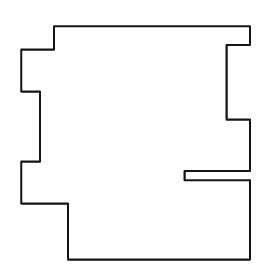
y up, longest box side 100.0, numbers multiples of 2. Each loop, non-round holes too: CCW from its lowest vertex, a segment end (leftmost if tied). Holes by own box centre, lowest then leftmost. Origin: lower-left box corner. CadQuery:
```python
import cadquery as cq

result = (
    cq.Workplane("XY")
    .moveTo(20.0, 0.0)
    .lineTo(98.0, 0.0)
    .lineTo(98.0, 34.0)
    .lineTo(70.0, 34.0)
    .lineTo(70.0, 38.0)
    .lineTo(98.0, 38.0)
    .lineTo(98.0, 60.0)
    .lineTo(88.0, 60.0)
    .lineTo(88.0, 92.0)
    .lineTo(98.0, 92.0)
    .lineTo(98.0, 100.0)
    .lineTo(14.0, 100.0)
    .lineTo(14.0, 90.0)
    .lineTo(0.0, 90.0)
    .lineTo(0.0, 72.0)
    .lineTo(8.0, 72.0)
    .lineTo(8.0, 42.0)
    .lineTo(0.0, 42.0)
    .lineTo(0.0, 24.0)
    .lineTo(20.0, 24.0)
    .close()
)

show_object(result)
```